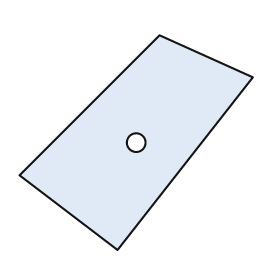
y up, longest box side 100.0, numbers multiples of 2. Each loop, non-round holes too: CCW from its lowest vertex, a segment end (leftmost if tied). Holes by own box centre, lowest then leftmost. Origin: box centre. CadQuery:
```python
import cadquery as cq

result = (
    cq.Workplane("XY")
    .moveTo(-8.0, -46.0)
    .lineTo(50.0, 28.0)
    .lineTo(10.0, 46.0)
    .lineTo(-50.0, -14.0)
    .close()
    .moveTo(0.0, 0.0)
    .circle(4.0)
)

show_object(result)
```